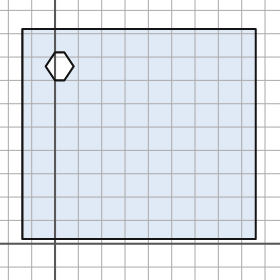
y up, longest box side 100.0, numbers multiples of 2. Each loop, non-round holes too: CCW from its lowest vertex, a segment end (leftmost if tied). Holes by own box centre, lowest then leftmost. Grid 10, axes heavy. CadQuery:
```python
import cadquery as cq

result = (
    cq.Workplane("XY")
    .moveTo(-14.0, 2.0)
    .lineTo(86.0, 2.0)
    .lineTo(86.0, 92.0)
    .lineTo(-14.0, 92.0)
    .close()
    .moveTo(0.0, 70.0)
    .lineTo(4.0, 70.0)
    .lineTo(8.0, 76.0)
    .lineTo(4.0, 82.0)
    .lineTo(0.0, 82.0)
    .lineTo(-4.0, 76.0)
    .close()
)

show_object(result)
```